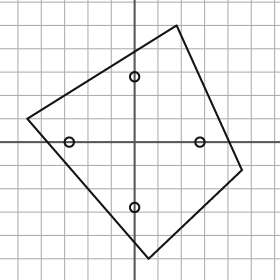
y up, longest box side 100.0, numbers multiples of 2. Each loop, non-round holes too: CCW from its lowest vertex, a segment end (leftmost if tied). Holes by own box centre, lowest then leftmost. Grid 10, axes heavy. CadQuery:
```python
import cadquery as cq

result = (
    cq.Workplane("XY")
    .moveTo(6.0, -50.0)
    .lineTo(46.0, -12.0)
    .lineTo(18.0, 50.0)
    .lineTo(-46.0, 10.0)
    .close()
    .moveTo(0.0, -28.0)
    .circle(2.0)
    .moveTo(-28.0, 0.0)
    .circle(2.0)
    .moveTo(28.0, 0.0)
    .circle(2.0)
    .moveTo(0.0, 28.0)
    .circle(2.0)
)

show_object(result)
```